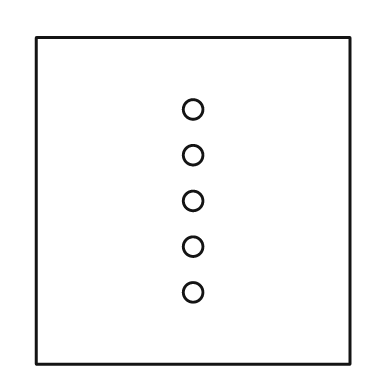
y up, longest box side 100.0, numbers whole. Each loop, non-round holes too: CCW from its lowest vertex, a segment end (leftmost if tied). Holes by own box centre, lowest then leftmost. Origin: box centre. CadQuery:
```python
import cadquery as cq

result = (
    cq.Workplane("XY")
    .moveTo(-48.0, -50.0)
    .lineTo(48.0, -50.0)
    .lineTo(48.0, 50.0)
    .lineTo(-48.0, 50.0)
    .close()
    .moveTo(0.0, -28.0)
    .circle(3.0)
    .moveTo(0.0, -14.0)
    .circle(3.0)
    .moveTo(0.0, 0.0)
    .circle(3.0)
    .moveTo(0.0, 14.0)
    .circle(3.0)
    .moveTo(0.0, 28.0)
    .circle(3.0)
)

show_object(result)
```